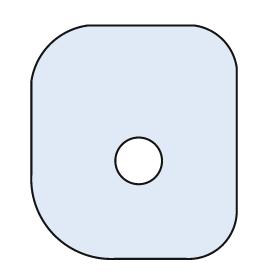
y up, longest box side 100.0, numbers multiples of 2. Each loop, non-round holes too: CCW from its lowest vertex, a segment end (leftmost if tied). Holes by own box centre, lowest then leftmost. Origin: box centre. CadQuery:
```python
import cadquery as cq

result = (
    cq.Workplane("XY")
    .moveTo(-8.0, -50.0)
    .lineTo(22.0, -50.0)
    .threePointArc((38.0, -44.0), (44.0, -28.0))
    .lineTo(44.0, 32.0)
    .threePointArc((38.0, 44.0), (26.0, 50.0))
    .lineTo(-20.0, 50.0)
    .threePointArc((-36.0, 42.0), (-44.0, 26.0))
    .lineTo(-44.0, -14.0)
    .threePointArc((-34.0, -40.0), (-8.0, -50.0))
    .close()
    .moveTo(2.0, -8.0)
    .circle(10.0)
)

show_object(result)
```